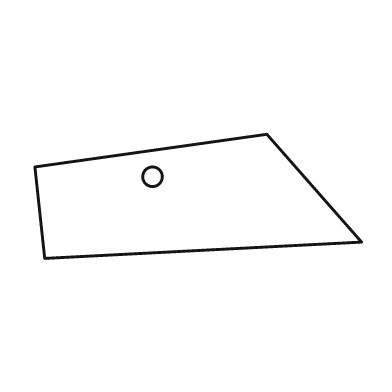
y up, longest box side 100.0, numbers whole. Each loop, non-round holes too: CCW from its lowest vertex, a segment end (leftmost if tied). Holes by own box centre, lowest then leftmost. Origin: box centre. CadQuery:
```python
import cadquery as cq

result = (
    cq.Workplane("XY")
    .moveTo(-47.0, -19.0)
    .lineTo(50.0, -14.0)
    .lineTo(21.0, 19.0)
    .lineTo(-50.0, 9.0)
    .close()
    .moveTo(-14.0, 6.0)
    .circle(3.0)
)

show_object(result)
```